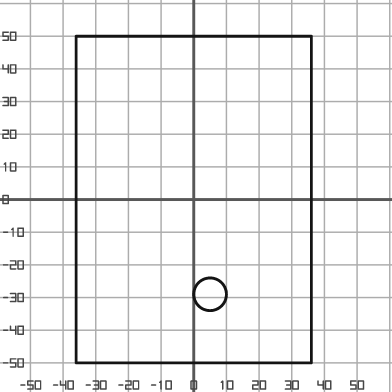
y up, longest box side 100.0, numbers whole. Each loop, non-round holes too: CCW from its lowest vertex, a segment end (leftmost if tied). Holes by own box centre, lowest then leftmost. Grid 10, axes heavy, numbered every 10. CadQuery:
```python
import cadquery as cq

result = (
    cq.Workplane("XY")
    .moveTo(-36.0, -50.0)
    .lineTo(36.0, -50.0)
    .lineTo(36.0, 50.0)
    .lineTo(-36.0, 50.0)
    .close()
    .moveTo(5.0, -29.0)
    .circle(5.0)
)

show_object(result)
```